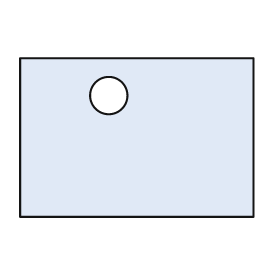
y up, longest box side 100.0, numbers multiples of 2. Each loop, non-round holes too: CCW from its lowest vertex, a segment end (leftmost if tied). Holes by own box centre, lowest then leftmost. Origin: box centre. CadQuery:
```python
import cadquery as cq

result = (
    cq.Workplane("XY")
    .moveTo(-50.0, -34.0)
    .lineTo(50.0, -34.0)
    .lineTo(50.0, 34.0)
    .lineTo(-50.0, 34.0)
    .close()
    .moveTo(-12.0, 18.0)
    .circle(8.0)
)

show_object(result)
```